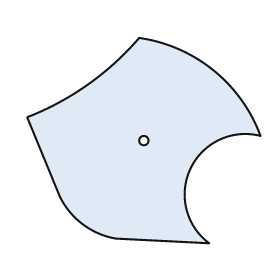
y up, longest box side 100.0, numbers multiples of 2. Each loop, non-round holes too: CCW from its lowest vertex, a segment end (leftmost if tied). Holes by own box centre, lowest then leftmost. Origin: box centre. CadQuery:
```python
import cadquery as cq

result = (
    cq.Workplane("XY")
    .moveTo(28.0, -44.0)
    .threePointArc((20.0, -12.0), (50.0, 2.0))
    .threePointArc((30.0, 30.0), (-2.0, 44.0))
    .threePointArc((-24.0, 24.0), (-50.0, 10.0))
    .lineTo(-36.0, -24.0)
    .threePointArc((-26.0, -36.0), (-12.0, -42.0))
    .close()
    .moveTo(0.0, 0.0)
    .circle(2.0)
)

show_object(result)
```